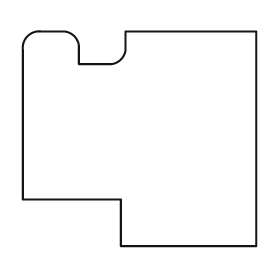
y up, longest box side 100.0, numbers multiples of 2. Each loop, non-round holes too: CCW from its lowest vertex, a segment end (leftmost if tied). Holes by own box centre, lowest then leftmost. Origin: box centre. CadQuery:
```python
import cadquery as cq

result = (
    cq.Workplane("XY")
    .moveTo(-8.0, -46.0)
    .lineTo(50.0, -46.0)
    .lineTo(50.0, 46.0)
    .lineTo(-6.0, 46.0)
    .lineTo(-6.0, 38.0)
    .threePointArc((-8.0, 34.0), (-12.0, 32.0))
    .lineTo(-26.0, 32.0)
    .lineTo(-26.0, 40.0)
    .threePointArc((-28.0, 44.0), (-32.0, 46.0))
    .lineTo(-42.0, 46.0)
    .threePointArc((-48.0, 44.0), (-50.0, 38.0))
    .lineTo(-50.0, -26.0)
    .lineTo(-8.0, -26.0)
    .close()
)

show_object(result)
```